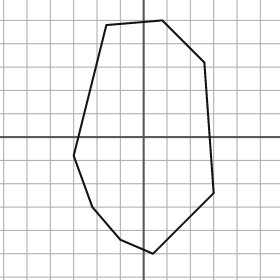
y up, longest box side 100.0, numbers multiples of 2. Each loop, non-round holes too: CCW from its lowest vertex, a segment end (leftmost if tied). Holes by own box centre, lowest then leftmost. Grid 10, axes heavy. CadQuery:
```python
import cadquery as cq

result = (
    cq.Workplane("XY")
    .moveTo(4.0, -50.0)
    .lineTo(30.0, -24.0)
    .lineTo(26.0, 32.0)
    .lineTo(8.0, 50.0)
    .lineTo(-16.0, 48.0)
    .lineTo(-30.0, -8.0)
    .lineTo(-22.0, -30.0)
    .lineTo(-10.0, -44.0)
    .close()
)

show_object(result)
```